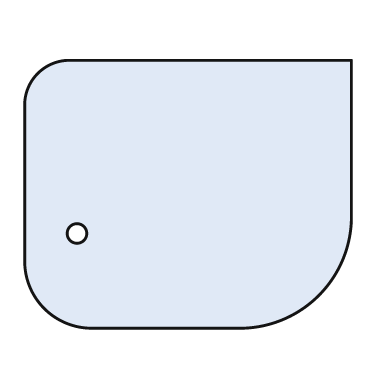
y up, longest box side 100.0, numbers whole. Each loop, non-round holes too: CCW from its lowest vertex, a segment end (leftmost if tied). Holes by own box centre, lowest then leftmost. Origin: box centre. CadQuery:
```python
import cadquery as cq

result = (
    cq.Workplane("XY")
    .moveTo(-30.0, -41.0)
    .lineTo(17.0, -41.0)
    .threePointArc((40.0, -31.0), (50.0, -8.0))
    .lineTo(50.0, 41.0)
    .lineTo(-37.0, 41.0)
    .threePointArc((-46.0, 37.0), (-50.0, 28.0))
    .lineTo(-50.0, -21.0)
    .threePointArc((-44.0, -35.0), (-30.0, -41.0))
    .close()
    .moveTo(-34.0, -12.0)
    .circle(3.0)
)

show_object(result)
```